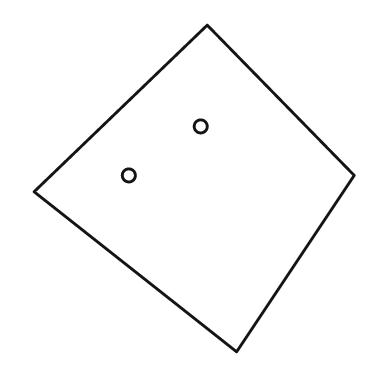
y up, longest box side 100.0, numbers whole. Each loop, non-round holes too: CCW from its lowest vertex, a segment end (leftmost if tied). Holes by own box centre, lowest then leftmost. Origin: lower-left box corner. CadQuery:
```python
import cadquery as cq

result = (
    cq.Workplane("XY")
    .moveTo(62.0, 0.0)
    .lineTo(98.0, 54.0)
    .lineTo(53.0, 100.0)
    .lineTo(0.0, 49.0)
    .close()
    .moveTo(29.0, 54.0)
    .circle(2.0)
    .moveTo(51.0, 69.0)
    .circle(2.0)
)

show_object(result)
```